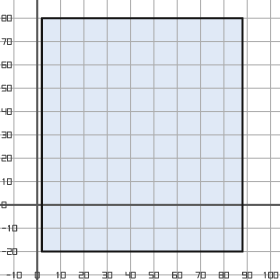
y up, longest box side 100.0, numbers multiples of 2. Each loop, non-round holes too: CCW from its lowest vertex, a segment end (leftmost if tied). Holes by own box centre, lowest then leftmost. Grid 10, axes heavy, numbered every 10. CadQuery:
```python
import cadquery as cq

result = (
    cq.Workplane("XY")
    .moveTo(2.0, -20.0)
    .lineTo(88.0, -20.0)
    .lineTo(88.0, 80.0)
    .lineTo(2.0, 80.0)
    .close()
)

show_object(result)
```